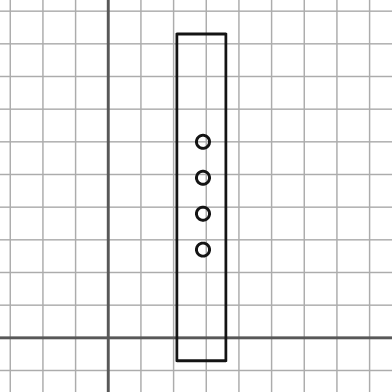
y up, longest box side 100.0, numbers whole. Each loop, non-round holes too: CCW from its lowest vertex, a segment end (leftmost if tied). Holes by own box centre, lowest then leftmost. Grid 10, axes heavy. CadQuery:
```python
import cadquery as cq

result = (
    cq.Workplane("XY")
    .moveTo(21.0, -7.0)
    .lineTo(36.0, -7.0)
    .lineTo(36.0, 93.0)
    .lineTo(21.0, 93.0)
    .close()
    .moveTo(29.0, 27.0)
    .circle(2.0)
    .moveTo(29.0, 38.0)
    .circle(2.0)
    .moveTo(29.0, 49.0)
    .circle(2.0)
    .moveTo(29.0, 60.0)
    .circle(2.0)
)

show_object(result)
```